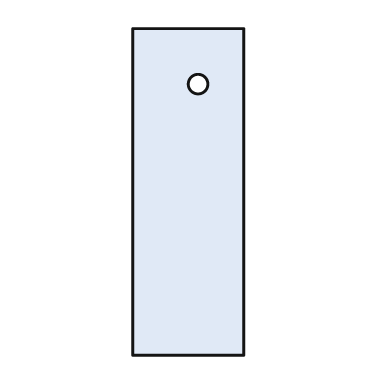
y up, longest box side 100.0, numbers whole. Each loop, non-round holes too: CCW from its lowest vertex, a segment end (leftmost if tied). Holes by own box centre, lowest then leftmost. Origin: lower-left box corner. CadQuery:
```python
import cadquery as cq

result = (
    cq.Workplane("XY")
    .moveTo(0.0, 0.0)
    .lineTo(34.0, 0.0)
    .lineTo(34.0, 100.0)
    .lineTo(0.0, 100.0)
    .close()
    .moveTo(20.0, 83.0)
    .circle(3.0)
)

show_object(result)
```